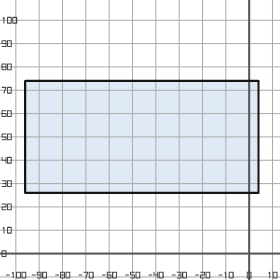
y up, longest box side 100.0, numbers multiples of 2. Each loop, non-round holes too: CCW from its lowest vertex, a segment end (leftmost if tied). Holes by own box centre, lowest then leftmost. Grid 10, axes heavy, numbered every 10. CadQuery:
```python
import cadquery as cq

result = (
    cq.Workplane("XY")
    .moveTo(-96.0, 26.0)
    .lineTo(4.0, 26.0)
    .lineTo(4.0, 74.0)
    .lineTo(-96.0, 74.0)
    .close()
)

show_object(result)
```